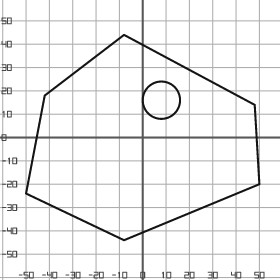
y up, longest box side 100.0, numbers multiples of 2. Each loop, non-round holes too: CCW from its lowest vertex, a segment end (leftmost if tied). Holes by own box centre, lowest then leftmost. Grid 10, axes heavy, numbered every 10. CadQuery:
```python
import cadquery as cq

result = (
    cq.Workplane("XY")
    .moveTo(-8.0, -44.0)
    .lineTo(50.0, -20.0)
    .lineTo(48.0, 14.0)
    .lineTo(-8.0, 44.0)
    .lineTo(-42.0, 18.0)
    .lineTo(-50.0, -24.0)
    .close()
    .moveTo(8.0, 16.0)
    .circle(8.0)
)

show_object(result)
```